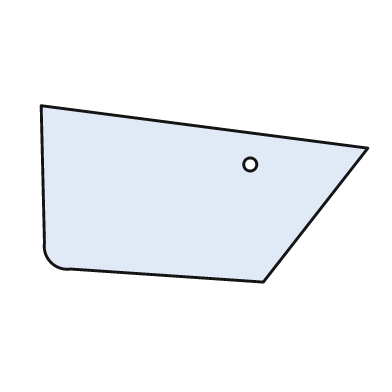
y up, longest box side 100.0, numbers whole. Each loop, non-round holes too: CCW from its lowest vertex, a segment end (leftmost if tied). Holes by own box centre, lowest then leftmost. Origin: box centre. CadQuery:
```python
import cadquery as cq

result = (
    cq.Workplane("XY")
    .moveTo(18.0, -27.0)
    .lineTo(50.0, 14.0)
    .lineTo(-50.0, 27.0)
    .lineTo(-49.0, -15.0)
    .threePointArc((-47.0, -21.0), (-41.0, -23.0))
    .close()
    .moveTo(14.0, 9.0)
    .circle(2.0)
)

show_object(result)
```